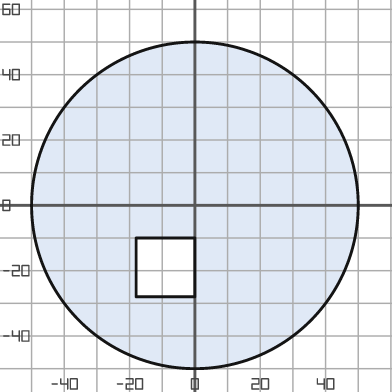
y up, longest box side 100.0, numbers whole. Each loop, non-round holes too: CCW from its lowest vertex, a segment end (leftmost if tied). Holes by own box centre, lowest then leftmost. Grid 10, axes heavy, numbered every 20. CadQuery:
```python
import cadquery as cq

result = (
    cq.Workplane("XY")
    .moveTo(0.0, 0.0)
    .circle(50.0)
    .moveTo(-18.0, -28.0)
    .lineTo(0.0, -28.0)
    .lineTo(0.0, -10.0)
    .lineTo(-18.0, -10.0)
    .close()
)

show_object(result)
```